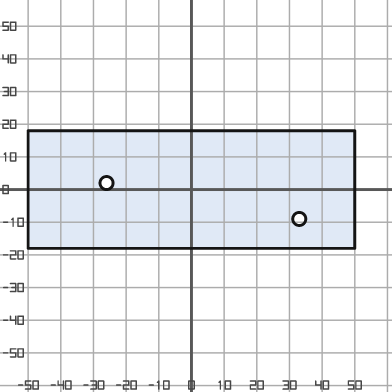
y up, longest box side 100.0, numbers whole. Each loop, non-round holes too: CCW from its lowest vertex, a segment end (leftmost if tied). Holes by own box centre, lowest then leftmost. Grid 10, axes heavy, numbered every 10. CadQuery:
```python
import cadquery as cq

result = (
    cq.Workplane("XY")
    .moveTo(-50.0, -18.0)
    .lineTo(50.0, -18.0)
    .lineTo(50.0, 18.0)
    .lineTo(-50.0, 18.0)
    .close()
    .moveTo(33.0, -9.0)
    .circle(2.0)
    .moveTo(-26.0, 2.0)
    .circle(2.0)
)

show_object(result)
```